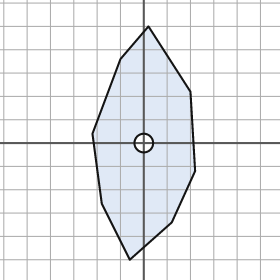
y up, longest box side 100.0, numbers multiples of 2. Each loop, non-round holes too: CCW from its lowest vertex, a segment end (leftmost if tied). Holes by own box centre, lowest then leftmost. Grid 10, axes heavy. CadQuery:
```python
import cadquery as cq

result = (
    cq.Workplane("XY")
    .moveTo(-6.0, -50.0)
    .lineTo(12.0, -34.0)
    .lineTo(22.0, -12.0)
    .lineTo(20.0, 22.0)
    .lineTo(2.0, 50.0)
    .lineTo(-10.0, 36.0)
    .lineTo(-22.0, 4.0)
    .lineTo(-18.0, -26.0)
    .close()
    .moveTo(0.0, 0.0)
    .circle(4.0)
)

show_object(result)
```